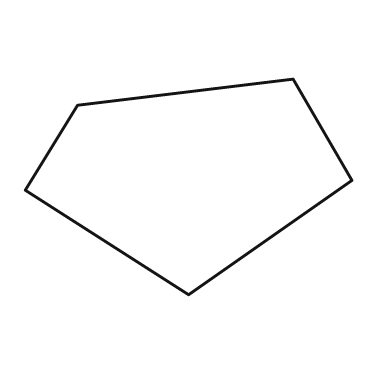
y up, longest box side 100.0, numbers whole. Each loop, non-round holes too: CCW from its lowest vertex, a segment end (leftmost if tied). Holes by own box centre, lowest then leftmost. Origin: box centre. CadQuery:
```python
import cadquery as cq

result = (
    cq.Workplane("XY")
    .moveTo(0.0, -33.0)
    .lineTo(50.0, 2.0)
    .lineTo(32.0, 33.0)
    .lineTo(-34.0, 25.0)
    .lineTo(-50.0, -1.0)
    .close()
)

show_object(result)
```